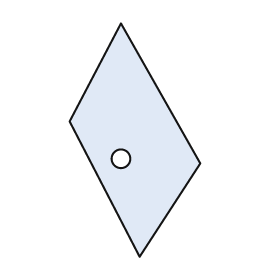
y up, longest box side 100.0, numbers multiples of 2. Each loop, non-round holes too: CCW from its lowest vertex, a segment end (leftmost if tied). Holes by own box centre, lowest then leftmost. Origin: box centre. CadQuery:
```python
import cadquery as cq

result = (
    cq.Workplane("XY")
    .moveTo(2.0, -50.0)
    .lineTo(28.0, -10.0)
    .lineTo(-6.0, 50.0)
    .lineTo(-28.0, 8.0)
    .close()
    .moveTo(-6.0, -8.0)
    .circle(4.0)
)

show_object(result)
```